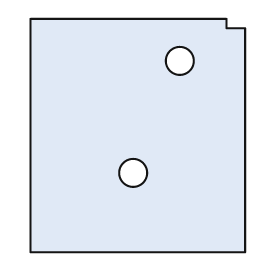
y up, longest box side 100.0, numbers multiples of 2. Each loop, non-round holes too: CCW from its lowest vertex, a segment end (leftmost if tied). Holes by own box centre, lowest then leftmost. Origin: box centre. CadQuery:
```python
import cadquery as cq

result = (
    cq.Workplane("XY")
    .moveTo(-46.0, -50.0)
    .lineTo(46.0, -50.0)
    .lineTo(46.0, 46.0)
    .lineTo(38.0, 46.0)
    .lineTo(38.0, 50.0)
    .lineTo(-46.0, 50.0)
    .close()
    .moveTo(-2.0, -16.0)
    .circle(6.0)
    .moveTo(18.0, 32.0)
    .circle(6.0)
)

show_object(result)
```